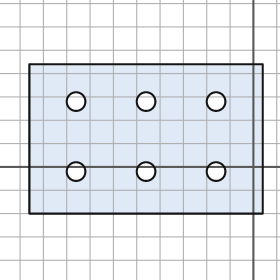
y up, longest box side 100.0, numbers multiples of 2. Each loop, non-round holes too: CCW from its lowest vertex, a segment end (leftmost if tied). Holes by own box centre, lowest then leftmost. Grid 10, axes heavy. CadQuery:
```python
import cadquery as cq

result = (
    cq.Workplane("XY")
    .moveTo(-96.0, -20.0)
    .lineTo(4.0, -20.0)
    .lineTo(4.0, 44.0)
    .lineTo(-96.0, 44.0)
    .close()
    .moveTo(-76.0, -2.0)
    .circle(4.0)
    .moveTo(-46.0, -2.0)
    .circle(4.0)
    .moveTo(-16.0, -2.0)
    .circle(4.0)
    .moveTo(-76.0, 28.0)
    .circle(4.0)
    .moveTo(-46.0, 28.0)
    .circle(4.0)
    .moveTo(-16.0, 28.0)
    .circle(4.0)
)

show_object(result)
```